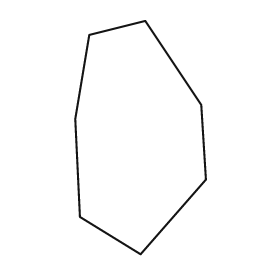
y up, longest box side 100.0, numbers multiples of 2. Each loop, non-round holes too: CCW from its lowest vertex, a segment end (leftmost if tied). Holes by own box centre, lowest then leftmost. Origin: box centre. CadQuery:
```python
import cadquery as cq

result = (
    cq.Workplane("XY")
    .moveTo(0.0, -50.0)
    .lineTo(28.0, -18.0)
    .lineTo(26.0, 14.0)
    .lineTo(2.0, 50.0)
    .lineTo(-22.0, 44.0)
    .lineTo(-28.0, 8.0)
    .lineTo(-26.0, -34.0)
    .close()
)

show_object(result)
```